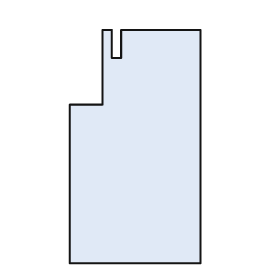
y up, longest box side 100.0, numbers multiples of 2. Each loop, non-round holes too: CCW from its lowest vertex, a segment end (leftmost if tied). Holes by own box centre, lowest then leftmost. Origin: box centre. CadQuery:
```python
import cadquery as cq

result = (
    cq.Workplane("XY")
    .moveTo(-28.0, -50.0)
    .lineTo(28.0, -50.0)
    .lineTo(28.0, 50.0)
    .lineTo(-6.0, 50.0)
    .lineTo(-6.0, 38.0)
    .lineTo(-10.0, 38.0)
    .lineTo(-10.0, 50.0)
    .lineTo(-14.0, 50.0)
    .lineTo(-14.0, 18.0)
    .lineTo(-28.0, 18.0)
    .close()
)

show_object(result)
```